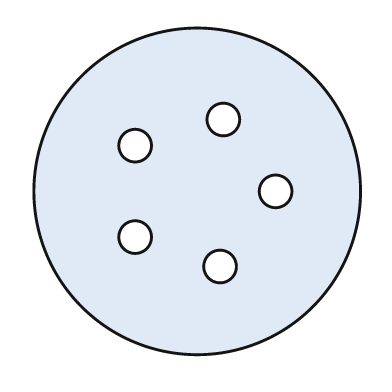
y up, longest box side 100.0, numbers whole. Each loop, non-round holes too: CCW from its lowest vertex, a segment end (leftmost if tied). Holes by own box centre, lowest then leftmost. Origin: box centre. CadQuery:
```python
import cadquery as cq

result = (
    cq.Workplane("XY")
    .moveTo(0.0, 0.0)
    .circle(50.0)
    .moveTo(7.0, -23.0)
    .circle(5.0)
    .moveTo(-19.0, -14.0)
    .circle(5.0)
    .moveTo(24.0, 0.0)
    .circle(5.0)
    .moveTo(-19.0, 14.0)
    .circle(5.0)
    .moveTo(8.0, 22.0)
    .circle(5.0)
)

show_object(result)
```